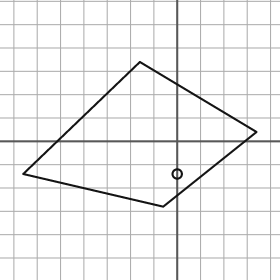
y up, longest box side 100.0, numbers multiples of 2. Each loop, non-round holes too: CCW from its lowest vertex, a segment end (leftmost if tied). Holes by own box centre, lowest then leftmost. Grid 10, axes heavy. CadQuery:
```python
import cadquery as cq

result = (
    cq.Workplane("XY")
    .moveTo(-6.0, -28.0)
    .lineTo(34.0, 4.0)
    .lineTo(-16.0, 34.0)
    .lineTo(-66.0, -14.0)
    .close()
    .moveTo(0.0, -14.0)
    .circle(2.0)
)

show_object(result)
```